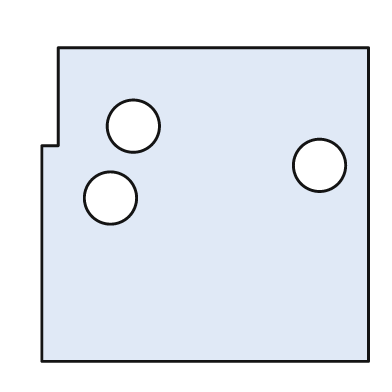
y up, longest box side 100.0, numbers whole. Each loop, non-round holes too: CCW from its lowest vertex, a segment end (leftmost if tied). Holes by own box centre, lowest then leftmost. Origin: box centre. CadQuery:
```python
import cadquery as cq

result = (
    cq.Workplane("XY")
    .moveTo(-50.0, -48.0)
    .lineTo(50.0, -48.0)
    .lineTo(50.0, 48.0)
    .lineTo(-45.0, 48.0)
    .lineTo(-45.0, 18.0)
    .lineTo(-50.0, 18.0)
    .close()
    .moveTo(-29.0, 2.0)
    .circle(8.0)
    .moveTo(35.0, 12.0)
    .circle(8.0)
    .moveTo(-22.0, 24.0)
    .circle(8.0)
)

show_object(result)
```